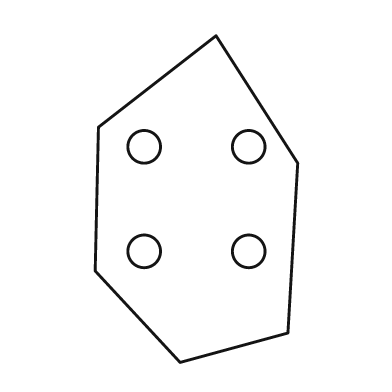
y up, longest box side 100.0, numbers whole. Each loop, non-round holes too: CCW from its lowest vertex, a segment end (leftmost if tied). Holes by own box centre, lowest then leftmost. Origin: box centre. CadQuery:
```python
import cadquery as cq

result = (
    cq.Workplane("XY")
    .moveTo(-5.0, -50.0)
    .lineTo(28.0, -41.0)
    .lineTo(31.0, 11.0)
    .lineTo(6.0, 50.0)
    .lineTo(-30.0, 22.0)
    .lineTo(-31.0, -22.0)
    .close()
    .moveTo(-16.0, -16.0)
    .circle(5.0)
    .moveTo(16.0, -16.0)
    .circle(5.0)
    .moveTo(-16.0, 16.0)
    .circle(5.0)
    .moveTo(16.0, 16.0)
    .circle(5.0)
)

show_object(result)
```